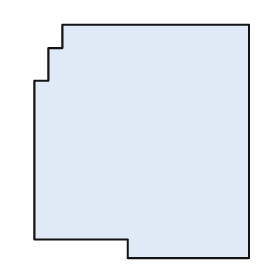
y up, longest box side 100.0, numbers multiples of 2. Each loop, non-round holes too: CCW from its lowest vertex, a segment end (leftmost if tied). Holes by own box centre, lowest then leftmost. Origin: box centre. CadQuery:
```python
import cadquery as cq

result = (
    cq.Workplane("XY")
    .moveTo(-6.0, -50.0)
    .lineTo(46.0, -50.0)
    .lineTo(46.0, 50.0)
    .lineTo(-34.0, 50.0)
    .lineTo(-34.0, 40.0)
    .lineTo(-40.0, 40.0)
    .lineTo(-40.0, 26.0)
    .lineTo(-46.0, 26.0)
    .lineTo(-46.0, -42.0)
    .lineTo(-6.0, -42.0)
    .close()
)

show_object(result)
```